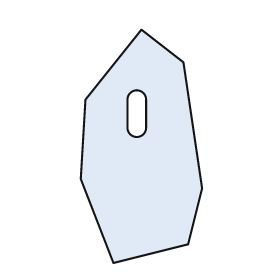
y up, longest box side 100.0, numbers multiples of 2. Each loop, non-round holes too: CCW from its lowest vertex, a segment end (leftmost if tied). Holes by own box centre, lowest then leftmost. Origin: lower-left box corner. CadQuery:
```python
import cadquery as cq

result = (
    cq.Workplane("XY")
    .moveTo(14.0, 0.0)
    .lineTo(46.0, 8.0)
    .lineTo(52.0, 32.0)
    .lineTo(44.0, 86.0)
    .lineTo(26.0, 100.0)
    .lineTo(2.0, 70.0)
    .lineTo(0.0, 36.0)
    .close()
    .moveTo(20.0, 58.0)
    .threePointArc((24.0, 54.0), (28.0, 58.0))
    .lineTo(28.0, 70.0)
    .threePointArc((24.0, 74.0), (20.0, 70.0))
    .close()
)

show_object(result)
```